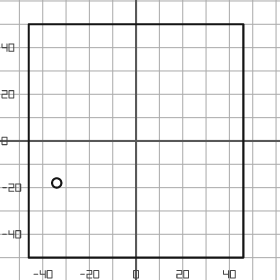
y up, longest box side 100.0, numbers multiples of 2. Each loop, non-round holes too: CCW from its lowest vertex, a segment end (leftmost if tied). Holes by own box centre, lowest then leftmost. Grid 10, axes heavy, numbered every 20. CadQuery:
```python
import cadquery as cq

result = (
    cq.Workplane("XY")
    .moveTo(-46.0, -50.0)
    .lineTo(46.0, -50.0)
    .lineTo(46.0, 50.0)
    .lineTo(-46.0, 50.0)
    .close()
    .moveTo(-34.0, -18.0)
    .circle(2.0)
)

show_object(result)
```